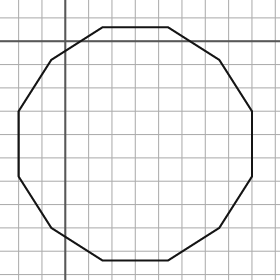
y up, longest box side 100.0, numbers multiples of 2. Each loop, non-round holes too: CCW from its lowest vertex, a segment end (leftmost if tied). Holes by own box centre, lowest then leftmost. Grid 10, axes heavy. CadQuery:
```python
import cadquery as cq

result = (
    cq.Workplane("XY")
    .moveTo(16.0, -94.0)
    .lineTo(44.0, -94.0)
    .lineTo(66.0, -80.0)
    .lineTo(80.0, -58.0)
    .lineTo(80.0, -30.0)
    .lineTo(66.0, -8.0)
    .lineTo(44.0, 6.0)
    .lineTo(16.0, 6.0)
    .lineTo(-6.0, -8.0)
    .lineTo(-20.0, -30.0)
    .lineTo(-20.0, -58.0)
    .lineTo(-6.0, -80.0)
    .close()
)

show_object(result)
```